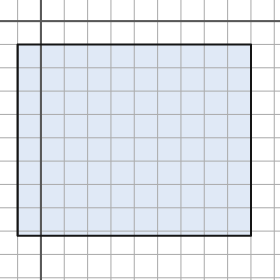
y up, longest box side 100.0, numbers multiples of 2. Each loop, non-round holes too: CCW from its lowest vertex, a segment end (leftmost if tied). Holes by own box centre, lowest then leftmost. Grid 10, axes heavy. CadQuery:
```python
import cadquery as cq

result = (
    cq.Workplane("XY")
    .moveTo(-10.0, -92.0)
    .lineTo(90.0, -92.0)
    .lineTo(90.0, -10.0)
    .lineTo(-10.0, -10.0)
    .close()
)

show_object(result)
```